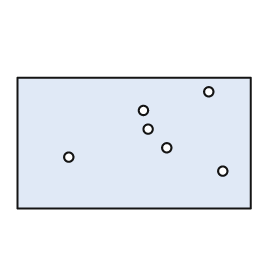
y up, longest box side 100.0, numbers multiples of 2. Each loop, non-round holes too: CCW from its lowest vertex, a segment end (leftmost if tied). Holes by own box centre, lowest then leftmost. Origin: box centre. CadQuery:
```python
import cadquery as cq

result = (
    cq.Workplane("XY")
    .moveTo(-50.0, -28.0)
    .lineTo(50.0, -28.0)
    .lineTo(50.0, 28.0)
    .lineTo(-50.0, 28.0)
    .close()
    .moveTo(38.0, -12.0)
    .circle(2.0)
    .moveTo(-28.0, -6.0)
    .circle(2.0)
    .moveTo(14.0, -2.0)
    .circle(2.0)
    .moveTo(6.0, 6.0)
    .circle(2.0)
    .moveTo(4.0, 14.0)
    .circle(2.0)
    .moveTo(32.0, 22.0)
    .circle(2.0)
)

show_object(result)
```